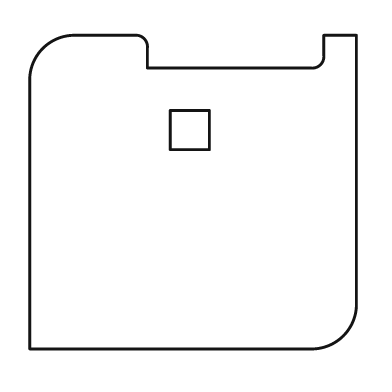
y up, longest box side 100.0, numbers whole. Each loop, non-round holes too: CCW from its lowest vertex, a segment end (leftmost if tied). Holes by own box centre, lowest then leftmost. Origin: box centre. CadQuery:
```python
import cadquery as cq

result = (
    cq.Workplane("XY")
    .moveTo(-50.0, -48.0)
    .lineTo(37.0, -48.0)
    .threePointArc((46.0, -44.0), (50.0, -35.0))
    .lineTo(50.0, 48.0)
    .lineTo(40.0, 48.0)
    .lineTo(40.0, 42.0)
    .threePointArc((39.0, 39.0), (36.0, 38.0))
    .lineTo(-14.0, 38.0)
    .lineTo(-14.0, 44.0)
    .threePointArc((-15.0, 47.0), (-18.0, 48.0))
    .lineTo(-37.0, 48.0)
    .threePointArc((-46.0, 44.0), (-50.0, 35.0))
    .close()
    .moveTo(-7.0, 13.0)
    .lineTo(5.0, 13.0)
    .lineTo(5.0, 25.0)
    .lineTo(-7.0, 25.0)
    .close()
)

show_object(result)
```